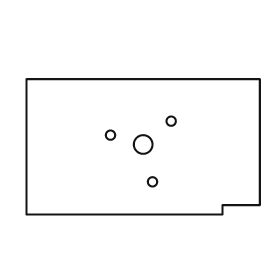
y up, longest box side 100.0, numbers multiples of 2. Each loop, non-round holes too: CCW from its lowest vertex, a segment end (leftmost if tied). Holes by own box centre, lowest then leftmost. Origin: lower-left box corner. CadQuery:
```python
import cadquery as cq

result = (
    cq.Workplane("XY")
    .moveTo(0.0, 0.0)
    .lineTo(84.0, 0.0)
    .lineTo(84.0, 4.0)
    .lineTo(100.0, 4.0)
    .lineTo(100.0, 58.0)
    .lineTo(0.0, 58.0)
    .close()
    .moveTo(54.0, 14.0)
    .circle(2.0)
    .moveTo(50.0, 30.0)
    .circle(4.0)
    .moveTo(36.0, 34.0)
    .circle(2.0)
    .moveTo(62.0, 40.0)
    .circle(2.0)
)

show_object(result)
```